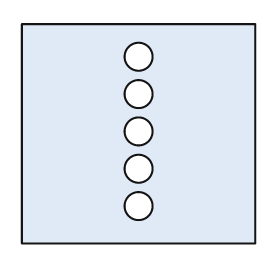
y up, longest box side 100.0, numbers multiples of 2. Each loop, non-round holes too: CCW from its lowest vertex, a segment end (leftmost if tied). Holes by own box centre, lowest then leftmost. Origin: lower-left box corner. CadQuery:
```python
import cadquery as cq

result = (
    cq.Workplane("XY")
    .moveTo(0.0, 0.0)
    .lineTo(100.0, 0.0)
    .lineTo(100.0, 94.0)
    .lineTo(0.0, 94.0)
    .close()
    .moveTo(50.0, 16.0)
    .circle(6.0)
    .moveTo(50.0, 32.0)
    .circle(6.0)
    .moveTo(50.0, 48.0)
    .circle(6.0)
    .moveTo(50.0, 64.0)
    .circle(6.0)
    .moveTo(50.0, 80.0)
    .circle(6.0)
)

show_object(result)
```